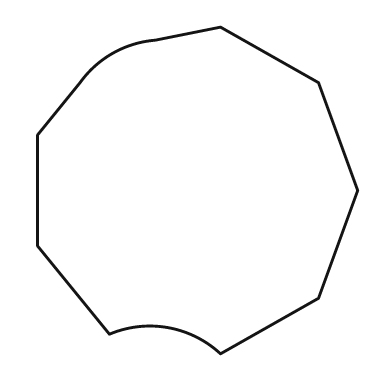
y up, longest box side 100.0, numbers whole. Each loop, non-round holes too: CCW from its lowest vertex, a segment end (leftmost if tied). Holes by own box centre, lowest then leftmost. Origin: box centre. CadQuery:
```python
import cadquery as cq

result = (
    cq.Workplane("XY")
    .moveTo(7.0, -50.0)
    .lineTo(37.0, -33.0)
    .lineTo(49.0, 0.0)
    .lineTo(37.0, 33.0)
    .lineTo(7.0, 50.0)
    .lineTo(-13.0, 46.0)
    .threePointArc((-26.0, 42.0), (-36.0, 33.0))
    .lineTo(-49.0, 17.0)
    .lineTo(-49.0, -17.0)
    .lineTo(-27.0, -44.0)
    .threePointArc((-9.0, -42.0), (7.0, -50.0))
    .close()
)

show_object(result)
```